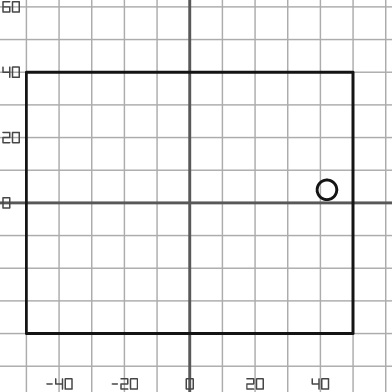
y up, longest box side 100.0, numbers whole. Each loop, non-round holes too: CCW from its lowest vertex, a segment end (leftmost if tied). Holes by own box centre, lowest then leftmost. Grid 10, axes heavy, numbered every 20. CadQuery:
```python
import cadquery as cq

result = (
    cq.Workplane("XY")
    .moveTo(-50.0, -40.0)
    .lineTo(50.0, -40.0)
    .lineTo(50.0, 40.0)
    .lineTo(-50.0, 40.0)
    .close()
    .moveTo(42.0, 4.0)
    .circle(3.0)
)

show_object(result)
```